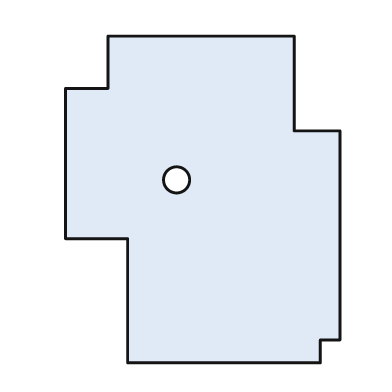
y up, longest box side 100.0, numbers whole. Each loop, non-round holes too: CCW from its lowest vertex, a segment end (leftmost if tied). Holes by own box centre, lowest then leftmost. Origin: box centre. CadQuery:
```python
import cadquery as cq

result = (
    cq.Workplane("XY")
    .moveTo(-23.0, -50.0)
    .lineTo(36.0, -50.0)
    .lineTo(36.0, -43.0)
    .lineTo(42.0, -43.0)
    .lineTo(42.0, 21.0)
    .lineTo(28.0, 21.0)
    .lineTo(28.0, 50.0)
    .lineTo(-29.0, 50.0)
    .lineTo(-29.0, 34.0)
    .lineTo(-42.0, 34.0)
    .lineTo(-42.0, -12.0)
    .lineTo(-23.0, -12.0)
    .close()
    .moveTo(-8.0, 6.0)
    .circle(4.0)
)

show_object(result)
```